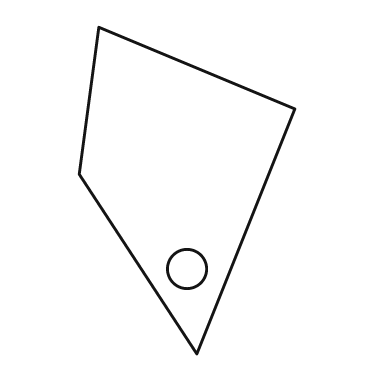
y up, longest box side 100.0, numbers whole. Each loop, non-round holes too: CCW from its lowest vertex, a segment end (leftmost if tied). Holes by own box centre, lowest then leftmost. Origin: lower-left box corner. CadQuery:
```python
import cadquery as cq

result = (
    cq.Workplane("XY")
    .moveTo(36.0, 0.0)
    .lineTo(66.0, 75.0)
    .lineTo(6.0, 100.0)
    .lineTo(0.0, 55.0)
    .close()
    .moveTo(33.0, 26.0)
    .circle(6.0)
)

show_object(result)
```